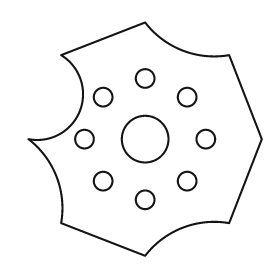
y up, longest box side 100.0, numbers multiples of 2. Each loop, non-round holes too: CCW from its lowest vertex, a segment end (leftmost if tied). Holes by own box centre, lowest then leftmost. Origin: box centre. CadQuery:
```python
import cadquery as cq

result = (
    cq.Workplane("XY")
    .moveTo(0.0, -50.0)
    .threePointArc((16.0, -38.0), (36.0, -36.0))
    .lineTo(50.0, 0.0)
    .lineTo(36.0, 36.0)
    .threePointArc((16.0, 38.0), (0.0, 50.0))
    .lineTo(-36.0, 36.0)
    .threePointArc((-28.0, 12.0), (-50.0, 0.0))
    .threePointArc((-38.0, -16.0), (-36.0, -36.0))
    .close()
    .moveTo(0.0, -26.0)
    .circle(4.0)
    .moveTo(-18.0, -18.0)
    .circle(4.0)
    .moveTo(18.0, -18.0)
    .circle(4.0)
    .moveTo(-26.0, 0.0)
    .circle(4.0)
    .moveTo(0.0, 0.0)
    .circle(10.0)
    .moveTo(26.0, 0.0)
    .circle(4.0)
    .moveTo(-18.0, 18.0)
    .circle(4.0)
    .moveTo(18.0, 18.0)
    .circle(4.0)
    .moveTo(0.0, 26.0)
    .circle(4.0)
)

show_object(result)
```